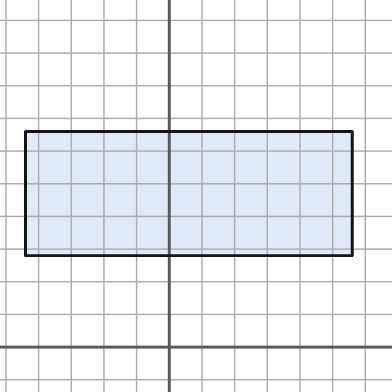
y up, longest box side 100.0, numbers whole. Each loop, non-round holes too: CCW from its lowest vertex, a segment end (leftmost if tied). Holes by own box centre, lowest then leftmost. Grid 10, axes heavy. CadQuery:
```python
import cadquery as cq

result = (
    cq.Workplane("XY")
    .moveTo(-44.0, 28.0)
    .lineTo(56.0, 28.0)
    .lineTo(56.0, 66.0)
    .lineTo(-44.0, 66.0)
    .close()
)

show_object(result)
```